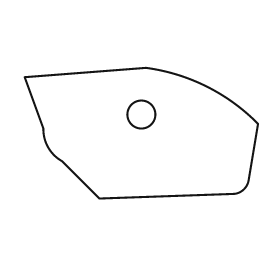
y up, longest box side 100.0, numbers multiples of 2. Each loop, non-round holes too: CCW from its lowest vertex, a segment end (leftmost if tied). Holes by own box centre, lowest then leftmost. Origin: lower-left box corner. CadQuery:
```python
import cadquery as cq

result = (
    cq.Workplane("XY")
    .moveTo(32.0, 0.0)
    .lineTo(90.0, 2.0)
    .threePointArc((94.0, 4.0), (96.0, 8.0))
    .lineTo(100.0, 32.0)
    .threePointArc((78.0, 48.0), (52.0, 56.0))
    .lineTo(0.0, 52.0)
    .lineTo(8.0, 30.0)
    .threePointArc((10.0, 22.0), (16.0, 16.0))
    .close()
    .moveTo(50.0, 36.0)
    .circle(6.0)
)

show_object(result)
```